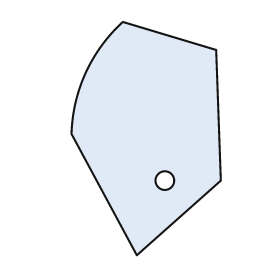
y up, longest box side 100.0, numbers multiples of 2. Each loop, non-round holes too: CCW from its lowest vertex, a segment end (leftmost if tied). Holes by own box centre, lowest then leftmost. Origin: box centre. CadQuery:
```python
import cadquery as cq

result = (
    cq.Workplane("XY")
    .moveTo(-4.0, -50.0)
    .lineTo(32.0, -18.0)
    .lineTo(30.0, 38.0)
    .lineTo(-10.0, 50.0)
    .threePointArc((-26.0, 28.0), (-32.0, 2.0))
    .close()
    .moveTo(8.0, -18.0)
    .circle(4.0)
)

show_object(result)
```